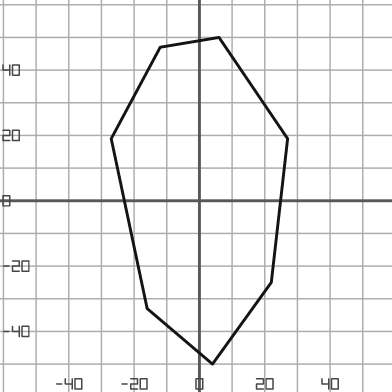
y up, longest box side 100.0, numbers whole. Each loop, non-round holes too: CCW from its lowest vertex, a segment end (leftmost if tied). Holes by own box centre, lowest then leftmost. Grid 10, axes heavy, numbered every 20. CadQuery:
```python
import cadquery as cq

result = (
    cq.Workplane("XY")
    .moveTo(4.0, -50.0)
    .lineTo(22.0, -25.0)
    .lineTo(27.0, 19.0)
    .lineTo(6.0, 50.0)
    .lineTo(-12.0, 47.0)
    .lineTo(-27.0, 19.0)
    .lineTo(-16.0, -33.0)
    .close()
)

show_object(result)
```